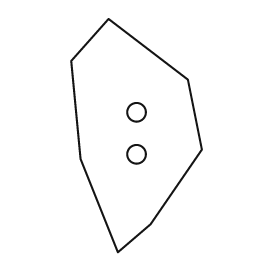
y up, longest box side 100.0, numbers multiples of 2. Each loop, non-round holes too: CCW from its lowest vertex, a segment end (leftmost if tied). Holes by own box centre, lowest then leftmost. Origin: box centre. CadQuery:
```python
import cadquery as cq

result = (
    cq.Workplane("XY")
    .moveTo(-8.0, -50.0)
    .lineTo(6.0, -38.0)
    .lineTo(28.0, -6.0)
    .lineTo(22.0, 24.0)
    .lineTo(-12.0, 50.0)
    .lineTo(-28.0, 32.0)
    .lineTo(-24.0, -10.0)
    .close()
    .moveTo(0.0, -8.0)
    .circle(4.0)
    .moveTo(0.0, 10.0)
    .circle(4.0)
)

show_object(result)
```